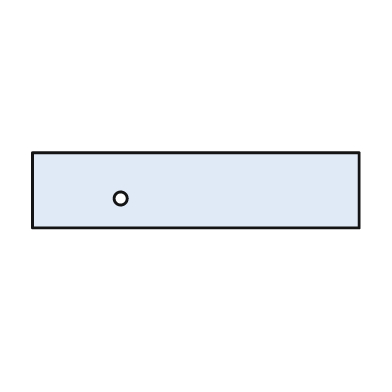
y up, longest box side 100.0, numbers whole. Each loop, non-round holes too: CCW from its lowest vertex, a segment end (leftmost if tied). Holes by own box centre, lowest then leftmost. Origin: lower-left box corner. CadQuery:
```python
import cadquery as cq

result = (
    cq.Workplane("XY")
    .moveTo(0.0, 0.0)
    .lineTo(100.0, 0.0)
    .lineTo(100.0, 23.0)
    .lineTo(0.0, 23.0)
    .close()
    .moveTo(27.0, 9.0)
    .circle(2.0)
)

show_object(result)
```